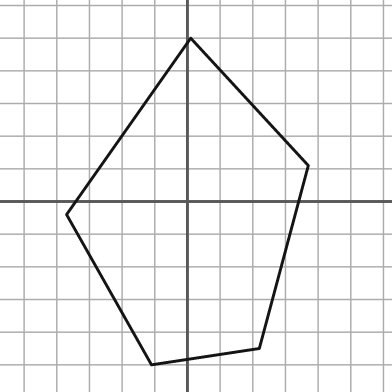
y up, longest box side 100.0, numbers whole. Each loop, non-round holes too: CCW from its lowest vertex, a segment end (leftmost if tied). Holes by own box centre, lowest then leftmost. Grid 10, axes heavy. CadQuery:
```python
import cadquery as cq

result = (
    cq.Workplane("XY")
    .moveTo(-11.0, -50.0)
    .lineTo(22.0, -45.0)
    .lineTo(37.0, 11.0)
    .lineTo(1.0, 50.0)
    .lineTo(-37.0, -4.0)
    .close()
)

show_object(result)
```